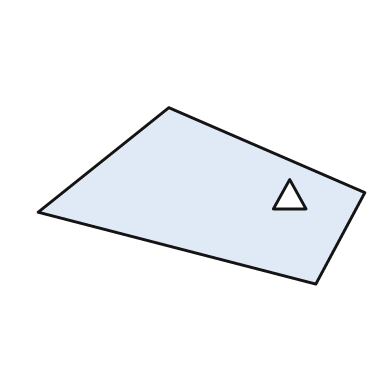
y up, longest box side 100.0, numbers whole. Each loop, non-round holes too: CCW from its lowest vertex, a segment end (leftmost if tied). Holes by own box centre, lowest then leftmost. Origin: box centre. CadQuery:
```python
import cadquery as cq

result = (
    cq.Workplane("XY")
    .moveTo(35.0, -27.0)
    .lineTo(50.0, 1.0)
    .lineTo(-10.0, 27.0)
    .lineTo(-50.0, -5.0)
    .close()
    .moveTo(22.0, -4.0)
    .lineTo(32.0, -4.0)
    .lineTo(27.0, 5.0)
    .close()
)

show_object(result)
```